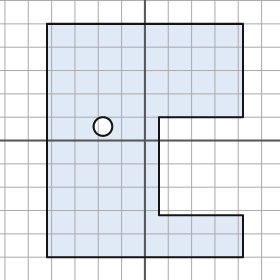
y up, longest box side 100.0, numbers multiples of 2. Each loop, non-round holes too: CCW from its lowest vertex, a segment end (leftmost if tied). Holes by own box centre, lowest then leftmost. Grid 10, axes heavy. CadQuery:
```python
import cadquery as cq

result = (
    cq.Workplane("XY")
    .moveTo(-42.0, -50.0)
    .lineTo(42.0, -50.0)
    .lineTo(42.0, -32.0)
    .lineTo(6.0, -32.0)
    .lineTo(6.0, 10.0)
    .lineTo(42.0, 10.0)
    .lineTo(42.0, 50.0)
    .lineTo(-42.0, 50.0)
    .close()
    .moveTo(-18.0, 6.0)
    .circle(4.0)
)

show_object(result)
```